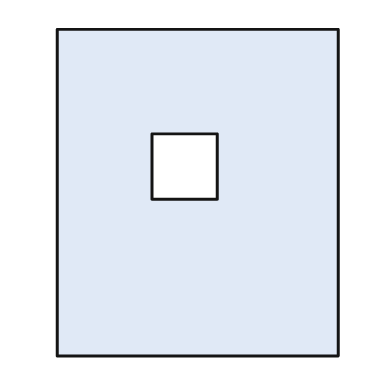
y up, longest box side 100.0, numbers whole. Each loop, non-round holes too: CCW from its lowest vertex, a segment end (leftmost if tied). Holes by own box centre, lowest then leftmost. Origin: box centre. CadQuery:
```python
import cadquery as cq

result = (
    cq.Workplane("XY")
    .moveTo(-43.0, -50.0)
    .lineTo(43.0, -50.0)
    .lineTo(43.0, 50.0)
    .lineTo(-43.0, 50.0)
    .close()
    .moveTo(-14.0, -2.0)
    .lineTo(6.0, -2.0)
    .lineTo(6.0, 18.0)
    .lineTo(-14.0, 18.0)
    .close()
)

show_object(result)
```